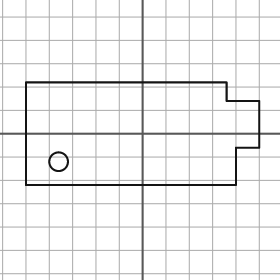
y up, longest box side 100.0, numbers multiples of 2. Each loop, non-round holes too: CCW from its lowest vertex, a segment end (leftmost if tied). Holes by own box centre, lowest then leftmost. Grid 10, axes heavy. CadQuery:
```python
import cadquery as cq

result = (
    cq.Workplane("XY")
    .moveTo(-50.0, -22.0)
    .lineTo(40.0, -22.0)
    .lineTo(40.0, -6.0)
    .lineTo(50.0, -6.0)
    .lineTo(50.0, 14.0)
    .lineTo(36.0, 14.0)
    .lineTo(36.0, 22.0)
    .lineTo(-50.0, 22.0)
    .close()
    .moveTo(-36.0, -12.0)
    .circle(4.0)
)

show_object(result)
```